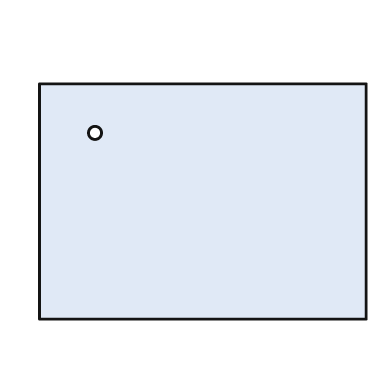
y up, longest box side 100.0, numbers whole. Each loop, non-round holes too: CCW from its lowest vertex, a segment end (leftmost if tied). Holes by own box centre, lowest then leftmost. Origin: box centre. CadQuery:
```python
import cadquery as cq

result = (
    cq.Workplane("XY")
    .moveTo(-50.0, -36.0)
    .lineTo(50.0, -36.0)
    .lineTo(50.0, 36.0)
    .lineTo(-50.0, 36.0)
    .close()
    .moveTo(-33.0, 21.0)
    .circle(2.0)
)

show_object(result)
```